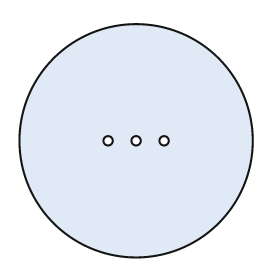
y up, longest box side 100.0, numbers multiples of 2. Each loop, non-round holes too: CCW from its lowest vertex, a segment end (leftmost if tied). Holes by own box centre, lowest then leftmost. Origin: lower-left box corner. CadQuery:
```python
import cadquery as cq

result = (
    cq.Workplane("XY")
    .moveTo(50.0, 50.0)
    .circle(50.0)
    .moveTo(38.0, 50.0)
    .circle(2.0)
    .moveTo(50.0, 50.0)
    .circle(2.0)
    .moveTo(62.0, 50.0)
    .circle(2.0)
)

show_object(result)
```